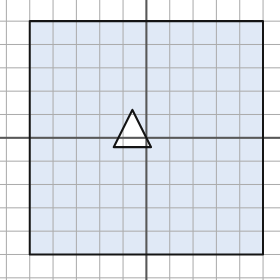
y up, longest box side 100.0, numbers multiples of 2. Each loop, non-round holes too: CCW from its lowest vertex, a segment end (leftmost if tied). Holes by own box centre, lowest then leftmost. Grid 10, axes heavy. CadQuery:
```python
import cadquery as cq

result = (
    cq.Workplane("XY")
    .moveTo(-50.0, -50.0)
    .lineTo(50.0, -50.0)
    .lineTo(50.0, 50.0)
    .lineTo(-50.0, 50.0)
    .close()
    .moveTo(-14.0, -4.0)
    .lineTo(2.0, -4.0)
    .lineTo(-6.0, 12.0)
    .close()
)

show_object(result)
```